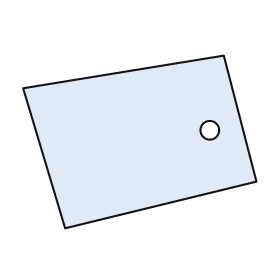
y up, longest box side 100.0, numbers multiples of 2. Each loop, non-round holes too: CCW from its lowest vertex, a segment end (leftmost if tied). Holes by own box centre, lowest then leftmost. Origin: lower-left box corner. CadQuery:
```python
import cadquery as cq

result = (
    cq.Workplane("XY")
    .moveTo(18.0, 0.0)
    .lineTo(100.0, 20.0)
    .lineTo(86.0, 74.0)
    .lineTo(0.0, 60.0)
    .close()
    .moveTo(80.0, 42.0)
    .circle(4.0)
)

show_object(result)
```